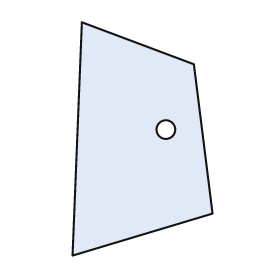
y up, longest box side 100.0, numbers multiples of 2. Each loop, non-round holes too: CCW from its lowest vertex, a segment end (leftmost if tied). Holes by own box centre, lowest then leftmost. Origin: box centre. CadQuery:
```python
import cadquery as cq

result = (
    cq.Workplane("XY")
    .moveTo(-30.0, -50.0)
    .lineTo(30.0, -32.0)
    .lineTo(22.0, 32.0)
    .lineTo(-26.0, 50.0)
    .close()
    .moveTo(10.0, 4.0)
    .circle(4.0)
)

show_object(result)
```